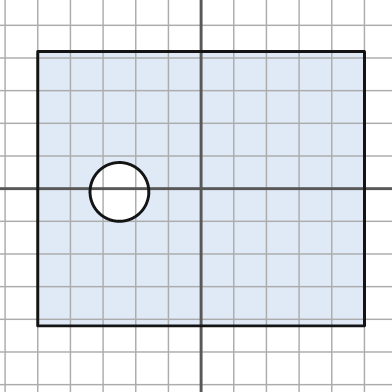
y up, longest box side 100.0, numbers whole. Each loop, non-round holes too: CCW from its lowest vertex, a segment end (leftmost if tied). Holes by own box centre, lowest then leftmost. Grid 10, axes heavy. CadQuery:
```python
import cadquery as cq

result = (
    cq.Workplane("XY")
    .moveTo(-50.0, -42.0)
    .lineTo(50.0, -42.0)
    .lineTo(50.0, 42.0)
    .lineTo(-50.0, 42.0)
    .close()
    .moveTo(-25.0, -1.0)
    .circle(9.0)
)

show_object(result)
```